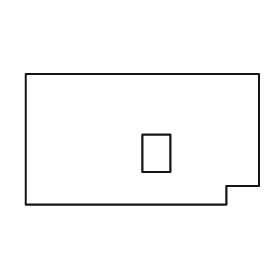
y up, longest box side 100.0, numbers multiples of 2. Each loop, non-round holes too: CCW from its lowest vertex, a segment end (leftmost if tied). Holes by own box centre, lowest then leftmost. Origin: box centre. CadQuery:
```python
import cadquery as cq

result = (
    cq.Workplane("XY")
    .moveTo(-50.0, -28.0)
    .lineTo(36.0, -28.0)
    .lineTo(36.0, -20.0)
    .lineTo(50.0, -20.0)
    .lineTo(50.0, 28.0)
    .lineTo(-50.0, 28.0)
    .close()
    .moveTo(0.0, -14.0)
    .lineTo(12.0, -14.0)
    .lineTo(12.0, 2.0)
    .lineTo(0.0, 2.0)
    .close()
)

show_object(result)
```